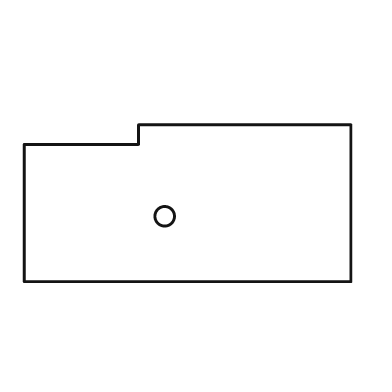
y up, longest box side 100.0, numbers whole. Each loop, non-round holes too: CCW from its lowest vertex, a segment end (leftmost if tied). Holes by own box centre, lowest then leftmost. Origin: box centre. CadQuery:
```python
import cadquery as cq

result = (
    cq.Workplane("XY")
    .moveTo(-50.0, -24.0)
    .lineTo(50.0, -24.0)
    .lineTo(50.0, 24.0)
    .lineTo(-15.0, 24.0)
    .lineTo(-15.0, 18.0)
    .lineTo(-50.0, 18.0)
    .close()
    .moveTo(-7.0, -4.0)
    .circle(3.0)
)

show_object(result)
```